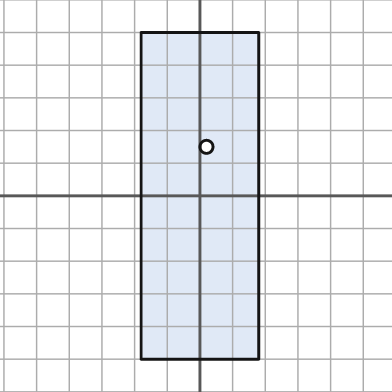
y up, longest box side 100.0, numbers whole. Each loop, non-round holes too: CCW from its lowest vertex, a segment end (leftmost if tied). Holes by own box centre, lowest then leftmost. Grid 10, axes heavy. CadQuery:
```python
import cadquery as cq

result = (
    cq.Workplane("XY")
    .moveTo(-18.0, -50.0)
    .lineTo(18.0, -50.0)
    .lineTo(18.0, 50.0)
    .lineTo(-18.0, 50.0)
    .close()
    .moveTo(2.0, 15.0)
    .circle(2.0)
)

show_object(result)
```